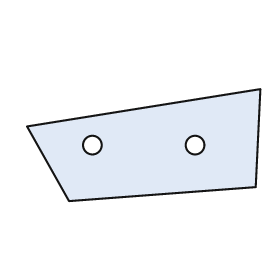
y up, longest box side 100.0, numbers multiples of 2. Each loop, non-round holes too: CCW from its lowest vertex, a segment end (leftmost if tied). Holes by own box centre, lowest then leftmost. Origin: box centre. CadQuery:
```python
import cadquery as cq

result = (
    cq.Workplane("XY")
    .moveTo(-32.0, -24.0)
    .lineTo(48.0, -18.0)
    .lineTo(50.0, 24.0)
    .lineTo(-50.0, 8.0)
    .close()
    .moveTo(-22.0, 0.0)
    .circle(4.0)
    .moveTo(22.0, 0.0)
    .circle(4.0)
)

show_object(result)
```